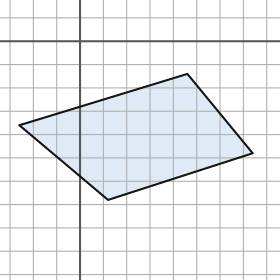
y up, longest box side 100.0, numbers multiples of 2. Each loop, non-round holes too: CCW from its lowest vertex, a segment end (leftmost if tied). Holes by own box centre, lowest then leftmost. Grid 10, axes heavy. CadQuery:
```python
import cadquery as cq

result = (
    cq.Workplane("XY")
    .moveTo(12.0, -68.0)
    .lineTo(74.0, -48.0)
    .lineTo(46.0, -14.0)
    .lineTo(-26.0, -36.0)
    .close()
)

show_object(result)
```